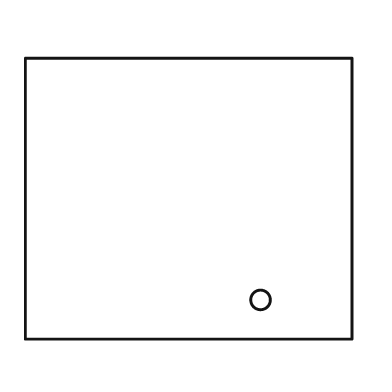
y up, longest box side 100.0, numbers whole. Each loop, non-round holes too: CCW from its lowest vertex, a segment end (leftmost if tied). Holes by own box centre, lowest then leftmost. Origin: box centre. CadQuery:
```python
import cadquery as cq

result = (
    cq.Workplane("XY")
    .moveTo(-50.0, -43.0)
    .lineTo(50.0, -43.0)
    .lineTo(50.0, 43.0)
    .lineTo(-50.0, 43.0)
    .close()
    .moveTo(22.0, -31.0)
    .circle(3.0)
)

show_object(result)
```